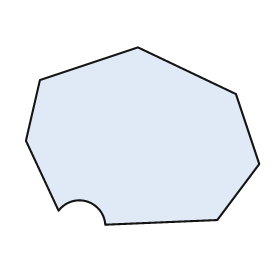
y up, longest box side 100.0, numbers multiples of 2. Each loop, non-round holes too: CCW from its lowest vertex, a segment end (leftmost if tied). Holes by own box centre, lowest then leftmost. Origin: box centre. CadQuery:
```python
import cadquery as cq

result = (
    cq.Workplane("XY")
    .moveTo(-16.0, -38.0)
    .lineTo(32.0, -36.0)
    .lineTo(50.0, -12.0)
    .lineTo(40.0, 18.0)
    .lineTo(-2.0, 38.0)
    .lineTo(-44.0, 24.0)
    .lineTo(-50.0, -2.0)
    .lineTo(-36.0, -32.0)
    .threePointArc((-24.0, -28.0), (-16.0, -38.0))
    .close()
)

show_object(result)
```